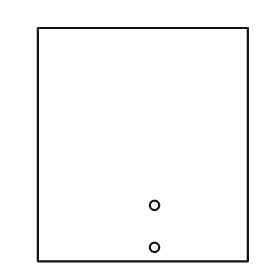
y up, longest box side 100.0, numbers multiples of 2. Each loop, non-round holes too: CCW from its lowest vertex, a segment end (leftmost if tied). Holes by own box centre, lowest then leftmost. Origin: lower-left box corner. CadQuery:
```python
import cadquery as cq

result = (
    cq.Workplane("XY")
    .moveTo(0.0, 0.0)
    .lineTo(90.0, 0.0)
    .lineTo(90.0, 100.0)
    .lineTo(0.0, 100.0)
    .close()
    .moveTo(50.0, 6.0)
    .circle(2.0)
    .moveTo(50.0, 24.0)
    .circle(2.0)
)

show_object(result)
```